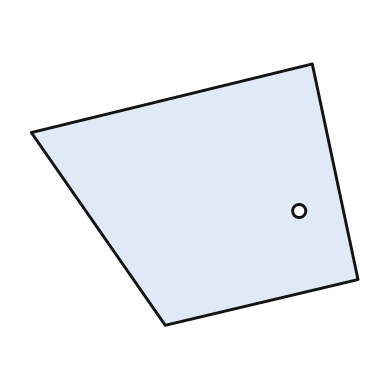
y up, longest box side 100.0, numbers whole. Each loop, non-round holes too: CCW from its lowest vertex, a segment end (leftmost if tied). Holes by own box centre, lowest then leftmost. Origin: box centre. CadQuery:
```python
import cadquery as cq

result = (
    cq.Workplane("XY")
    .moveTo(-9.0, -40.0)
    .lineTo(50.0, -26.0)
    .lineTo(36.0, 40.0)
    .lineTo(-50.0, 19.0)
    .close()
    .moveTo(32.0, -5.0)
    .circle(2.0)
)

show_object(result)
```